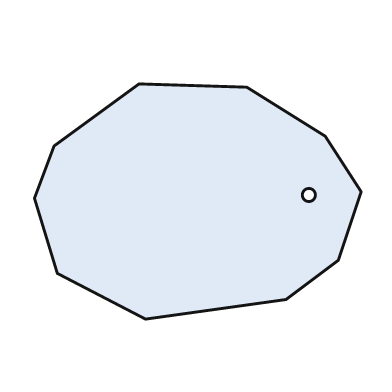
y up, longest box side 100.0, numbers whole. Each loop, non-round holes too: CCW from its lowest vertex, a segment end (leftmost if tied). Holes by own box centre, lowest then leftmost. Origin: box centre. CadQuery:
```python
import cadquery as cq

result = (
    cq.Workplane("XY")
    .moveTo(-16.0, -36.0)
    .lineTo(27.0, -30.0)
    .lineTo(43.0, -18.0)
    .lineTo(50.0, 3.0)
    .lineTo(39.0, 20.0)
    .lineTo(15.0, 35.0)
    .lineTo(-18.0, 36.0)
    .lineTo(-44.0, 17.0)
    .lineTo(-50.0, 1.0)
    .lineTo(-43.0, -22.0)
    .close()
    .moveTo(34.0, 2.0)
    .circle(2.0)
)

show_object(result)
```